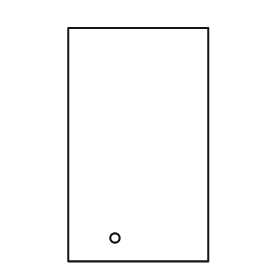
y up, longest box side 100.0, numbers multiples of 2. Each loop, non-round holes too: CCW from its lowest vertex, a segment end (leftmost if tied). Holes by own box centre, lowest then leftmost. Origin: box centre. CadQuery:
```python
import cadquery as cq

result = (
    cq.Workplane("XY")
    .moveTo(-30.0, -50.0)
    .lineTo(30.0, -50.0)
    .lineTo(30.0, 50.0)
    .lineTo(-30.0, 50.0)
    .close()
    .moveTo(-10.0, -40.0)
    .circle(2.0)
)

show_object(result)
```